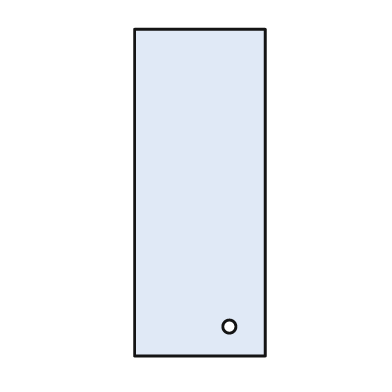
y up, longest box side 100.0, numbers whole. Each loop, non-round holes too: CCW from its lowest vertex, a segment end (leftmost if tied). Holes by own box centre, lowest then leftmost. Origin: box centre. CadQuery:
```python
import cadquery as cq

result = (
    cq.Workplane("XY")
    .moveTo(-20.0, -50.0)
    .lineTo(20.0, -50.0)
    .lineTo(20.0, 50.0)
    .lineTo(-20.0, 50.0)
    .close()
    .moveTo(9.0, -41.0)
    .circle(2.0)
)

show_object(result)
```